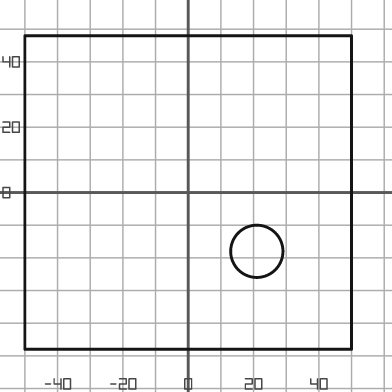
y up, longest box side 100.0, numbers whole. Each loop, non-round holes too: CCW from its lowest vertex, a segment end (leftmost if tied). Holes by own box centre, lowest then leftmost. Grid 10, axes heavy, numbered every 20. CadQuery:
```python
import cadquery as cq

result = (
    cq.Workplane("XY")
    .moveTo(-50.0, -48.0)
    .lineTo(50.0, -48.0)
    .lineTo(50.0, 48.0)
    .lineTo(-50.0, 48.0)
    .close()
    .moveTo(21.0, -18.0)
    .circle(8.0)
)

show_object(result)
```